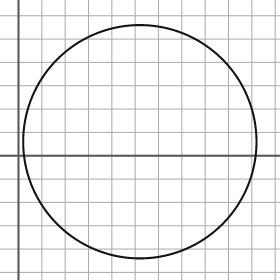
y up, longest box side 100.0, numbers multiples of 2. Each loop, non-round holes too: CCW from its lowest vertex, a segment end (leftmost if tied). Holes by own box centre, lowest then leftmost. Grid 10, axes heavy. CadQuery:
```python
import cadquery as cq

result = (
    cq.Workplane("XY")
    .moveTo(52.0, 6.0)
    .circle(50.0)
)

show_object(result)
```